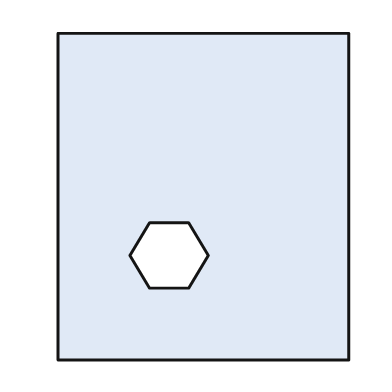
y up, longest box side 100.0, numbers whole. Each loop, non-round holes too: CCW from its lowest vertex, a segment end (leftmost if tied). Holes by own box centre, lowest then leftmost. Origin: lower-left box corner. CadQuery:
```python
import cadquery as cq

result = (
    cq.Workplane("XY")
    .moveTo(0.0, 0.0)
    .lineTo(89.0, 0.0)
    .lineTo(89.0, 100.0)
    .lineTo(0.0, 100.0)
    .close()
    .moveTo(28.0, 22.0)
    .lineTo(40.0, 22.0)
    .lineTo(46.0, 32.0)
    .lineTo(40.0, 42.0)
    .lineTo(28.0, 42.0)
    .lineTo(22.0, 32.0)
    .close()
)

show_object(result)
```